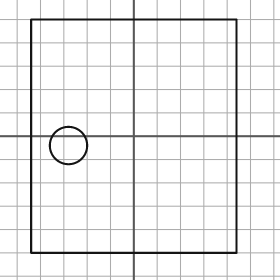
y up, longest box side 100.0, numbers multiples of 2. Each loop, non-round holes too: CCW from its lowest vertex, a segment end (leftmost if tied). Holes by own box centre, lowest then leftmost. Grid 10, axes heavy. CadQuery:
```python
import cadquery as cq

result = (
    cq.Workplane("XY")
    .moveTo(-44.0, -50.0)
    .lineTo(44.0, -50.0)
    .lineTo(44.0, 50.0)
    .lineTo(-44.0, 50.0)
    .close()
    .moveTo(-28.0, -4.0)
    .circle(8.0)
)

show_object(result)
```